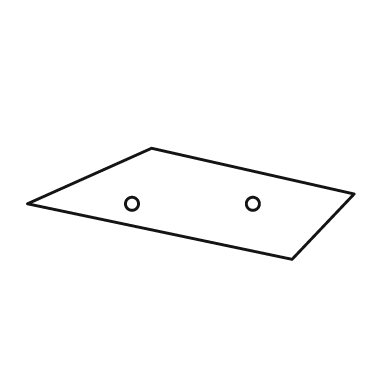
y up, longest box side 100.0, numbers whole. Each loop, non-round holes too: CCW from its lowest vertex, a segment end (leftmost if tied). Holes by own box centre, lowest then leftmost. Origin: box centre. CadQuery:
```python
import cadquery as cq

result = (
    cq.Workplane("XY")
    .moveTo(31.0, -17.0)
    .lineTo(50.0, 3.0)
    .lineTo(-12.0, 17.0)
    .lineTo(-50.0, 0.0)
    .close()
    .moveTo(-18.0, 0.0)
    .circle(2.0)
    .moveTo(19.0, 0.0)
    .circle(2.0)
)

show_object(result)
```